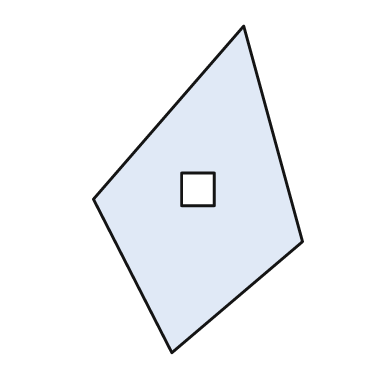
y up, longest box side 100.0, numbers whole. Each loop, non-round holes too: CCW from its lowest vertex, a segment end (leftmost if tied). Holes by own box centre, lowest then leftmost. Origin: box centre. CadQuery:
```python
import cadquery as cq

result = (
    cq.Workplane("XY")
    .moveTo(-8.0, -50.0)
    .lineTo(32.0, -16.0)
    .lineTo(14.0, 50.0)
    .lineTo(-32.0, -3.0)
    .close()
    .moveTo(-5.0, -5.0)
    .lineTo(5.0, -5.0)
    .lineTo(5.0, 5.0)
    .lineTo(-5.0, 5.0)
    .close()
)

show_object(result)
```